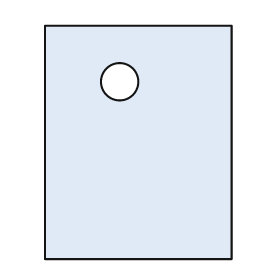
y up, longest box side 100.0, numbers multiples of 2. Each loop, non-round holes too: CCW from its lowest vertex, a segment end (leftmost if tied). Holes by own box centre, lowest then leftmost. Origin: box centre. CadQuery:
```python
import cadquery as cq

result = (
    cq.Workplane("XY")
    .moveTo(-40.0, -50.0)
    .lineTo(40.0, -50.0)
    .lineTo(40.0, 50.0)
    .lineTo(-40.0, 50.0)
    .close()
    .moveTo(-8.0, 26.0)
    .circle(8.0)
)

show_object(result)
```